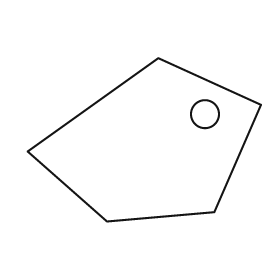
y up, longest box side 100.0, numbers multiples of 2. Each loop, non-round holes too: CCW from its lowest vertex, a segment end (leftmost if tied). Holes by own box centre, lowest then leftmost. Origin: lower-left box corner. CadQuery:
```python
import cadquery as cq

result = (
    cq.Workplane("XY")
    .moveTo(34.0, 0.0)
    .lineTo(80.0, 4.0)
    .lineTo(100.0, 50.0)
    .lineTo(56.0, 70.0)
    .lineTo(0.0, 30.0)
    .close()
    .moveTo(76.0, 46.0)
    .circle(6.0)
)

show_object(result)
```